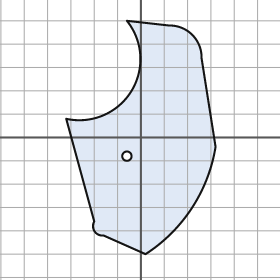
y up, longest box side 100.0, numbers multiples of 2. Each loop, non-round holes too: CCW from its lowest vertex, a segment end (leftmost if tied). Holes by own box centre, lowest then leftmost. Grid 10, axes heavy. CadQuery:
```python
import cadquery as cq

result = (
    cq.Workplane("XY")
    .moveTo(2.0, -50.0)
    .threePointArc((22.0, -30.0), (32.0, -4.0))
    .lineTo(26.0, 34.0)
    .threePointArc((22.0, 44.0), (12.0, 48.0))
    .lineTo(-6.0, 50.0)
    .threePointArc((-4.0, 20.0), (-32.0, 8.0))
    .lineTo(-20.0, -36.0)
    .threePointArc((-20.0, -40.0), (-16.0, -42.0))
    .close()
    .moveTo(-6.0, -8.0)
    .circle(2.0)
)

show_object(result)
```